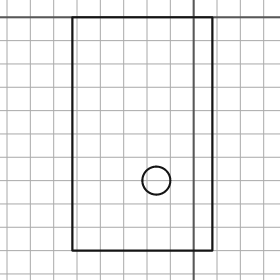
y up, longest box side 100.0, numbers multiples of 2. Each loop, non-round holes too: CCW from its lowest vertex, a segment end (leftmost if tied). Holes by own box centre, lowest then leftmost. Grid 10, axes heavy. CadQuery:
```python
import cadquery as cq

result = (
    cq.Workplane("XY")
    .moveTo(-52.0, -100.0)
    .lineTo(8.0, -100.0)
    .lineTo(8.0, 0.0)
    .lineTo(-52.0, 0.0)
    .close()
    .moveTo(-16.0, -70.0)
    .circle(6.0)
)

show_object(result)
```